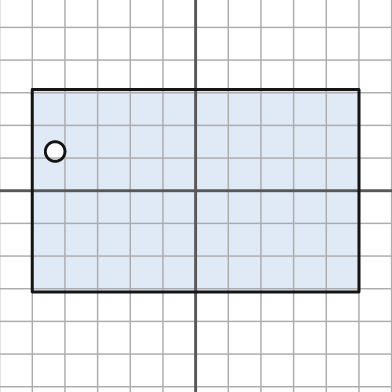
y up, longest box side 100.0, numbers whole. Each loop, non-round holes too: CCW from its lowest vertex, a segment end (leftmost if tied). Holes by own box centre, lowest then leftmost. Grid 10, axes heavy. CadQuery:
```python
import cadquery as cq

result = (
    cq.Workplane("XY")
    .moveTo(-50.0, -31.0)
    .lineTo(50.0, -31.0)
    .lineTo(50.0, 31.0)
    .lineTo(-50.0, 31.0)
    .close()
    .moveTo(-43.0, 12.0)
    .circle(3.0)
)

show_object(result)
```